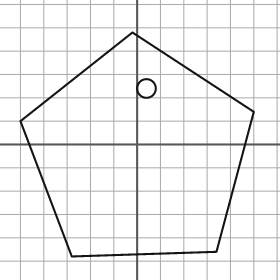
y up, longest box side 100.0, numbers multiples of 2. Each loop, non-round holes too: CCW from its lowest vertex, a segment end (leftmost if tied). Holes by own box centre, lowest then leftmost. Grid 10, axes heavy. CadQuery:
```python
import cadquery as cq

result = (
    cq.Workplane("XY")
    .moveTo(-28.0, -48.0)
    .lineTo(34.0, -46.0)
    .lineTo(50.0, 14.0)
    .lineTo(-2.0, 48.0)
    .lineTo(-50.0, 10.0)
    .close()
    .moveTo(4.0, 24.0)
    .circle(4.0)
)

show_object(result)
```